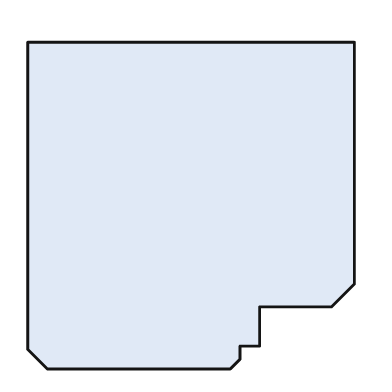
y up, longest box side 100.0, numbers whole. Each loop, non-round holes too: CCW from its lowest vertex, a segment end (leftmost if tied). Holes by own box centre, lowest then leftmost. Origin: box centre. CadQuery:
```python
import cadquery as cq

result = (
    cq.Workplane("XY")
    .moveTo(-44.0, -50.0)
    .lineTo(12.0, -50.0)
    .lineTo(15.0, -47.0)
    .lineTo(15.0, -43.0)
    .lineTo(21.0, -43.0)
    .lineTo(21.0, -31.0)
    .lineTo(43.0, -31.0)
    .lineTo(50.0, -24.0)
    .lineTo(50.0, 50.0)
    .lineTo(-50.0, 50.0)
    .lineTo(-50.0, -44.0)
    .close()
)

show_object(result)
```